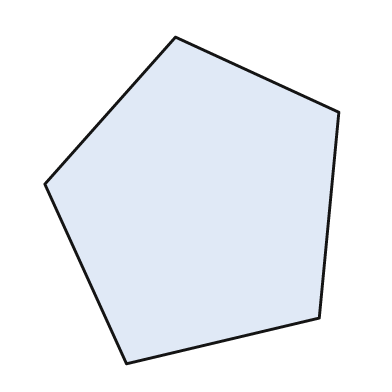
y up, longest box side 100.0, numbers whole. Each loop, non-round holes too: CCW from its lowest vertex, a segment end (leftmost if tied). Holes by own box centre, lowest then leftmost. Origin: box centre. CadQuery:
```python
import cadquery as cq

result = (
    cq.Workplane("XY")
    .moveTo(-20.0, -50.0)
    .lineTo(39.0, -36.0)
    .lineTo(45.0, 27.0)
    .lineTo(-5.0, 50.0)
    .lineTo(-45.0, 5.0)
    .close()
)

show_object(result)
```